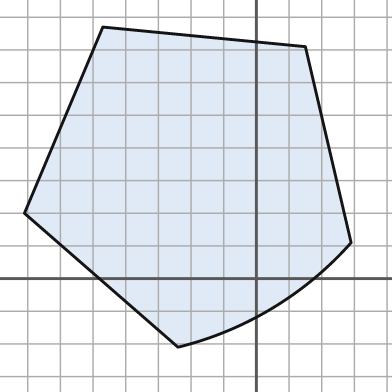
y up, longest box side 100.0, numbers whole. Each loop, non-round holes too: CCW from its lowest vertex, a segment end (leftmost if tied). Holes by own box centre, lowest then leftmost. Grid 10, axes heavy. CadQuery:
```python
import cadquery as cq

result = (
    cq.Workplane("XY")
    .moveTo(-24.0, -21.0)
    .threePointArc((5.0, -9.0), (29.0, 11.0))
    .lineTo(15.0, 71.0)
    .lineTo(-47.0, 77.0)
    .lineTo(-71.0, 20.0)
    .close()
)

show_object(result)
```